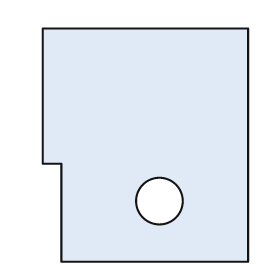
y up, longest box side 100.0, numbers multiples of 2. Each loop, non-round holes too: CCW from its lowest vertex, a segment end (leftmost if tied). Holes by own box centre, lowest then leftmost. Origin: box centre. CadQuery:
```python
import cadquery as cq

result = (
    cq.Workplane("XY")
    .moveTo(-36.0, -50.0)
    .lineTo(44.0, -50.0)
    .lineTo(44.0, 50.0)
    .lineTo(-44.0, 50.0)
    .lineTo(-44.0, -8.0)
    .lineTo(-36.0, -8.0)
    .close()
    .moveTo(6.0, -24.0)
    .circle(10.0)
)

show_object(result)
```